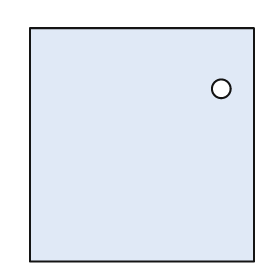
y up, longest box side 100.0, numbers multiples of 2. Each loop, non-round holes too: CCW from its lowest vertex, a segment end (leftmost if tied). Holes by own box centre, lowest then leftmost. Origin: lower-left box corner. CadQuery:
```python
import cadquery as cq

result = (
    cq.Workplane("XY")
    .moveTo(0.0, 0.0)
    .lineTo(96.0, 0.0)
    .lineTo(96.0, 100.0)
    .lineTo(0.0, 100.0)
    .close()
    .moveTo(82.0, 74.0)
    .circle(4.0)
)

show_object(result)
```